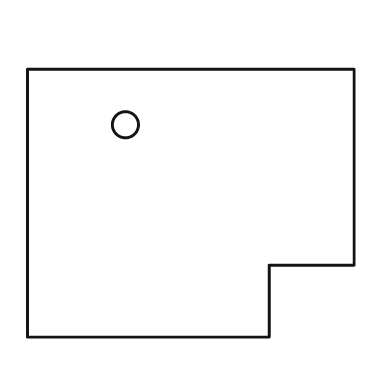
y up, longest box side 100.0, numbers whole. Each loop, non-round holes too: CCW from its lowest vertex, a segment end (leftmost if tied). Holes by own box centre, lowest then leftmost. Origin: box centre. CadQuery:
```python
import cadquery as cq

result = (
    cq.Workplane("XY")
    .moveTo(-50.0, -41.0)
    .lineTo(24.0, -41.0)
    .lineTo(24.0, -19.0)
    .lineTo(50.0, -19.0)
    .lineTo(50.0, 41.0)
    .lineTo(-50.0, 41.0)
    .close()
    .moveTo(-20.0, 24.0)
    .circle(4.0)
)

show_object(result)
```